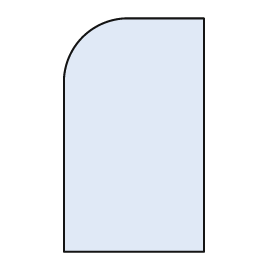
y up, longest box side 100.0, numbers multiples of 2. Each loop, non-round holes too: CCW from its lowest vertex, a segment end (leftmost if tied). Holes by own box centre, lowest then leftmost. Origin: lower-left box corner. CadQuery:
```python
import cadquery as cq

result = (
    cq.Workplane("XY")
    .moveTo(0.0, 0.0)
    .lineTo(60.0, 0.0)
    .lineTo(60.0, 100.0)
    .lineTo(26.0, 100.0)
    .threePointArc((8.0, 92.0), (0.0, 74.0))
    .close()
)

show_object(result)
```